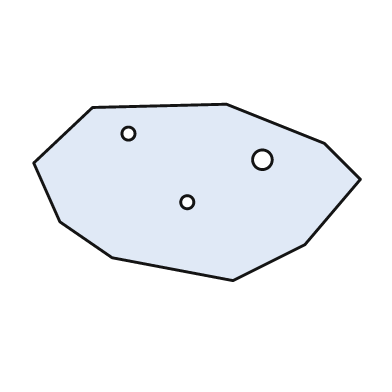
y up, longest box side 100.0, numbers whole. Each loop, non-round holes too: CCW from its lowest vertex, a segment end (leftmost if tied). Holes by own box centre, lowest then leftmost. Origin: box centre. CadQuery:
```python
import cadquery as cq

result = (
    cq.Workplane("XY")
    .moveTo(11.0, -27.0)
    .lineTo(33.0, -16.0)
    .lineTo(50.0, 4.0)
    .lineTo(39.0, 15.0)
    .lineTo(9.0, 27.0)
    .lineTo(-32.0, 26.0)
    .lineTo(-50.0, 9.0)
    .lineTo(-42.0, -9.0)
    .lineTo(-26.0, -20.0)
    .close()
    .moveTo(-3.0, -3.0)
    .circle(2.0)
    .moveTo(20.0, 10.0)
    .circle(3.0)
    .moveTo(-21.0, 18.0)
    .circle(2.0)
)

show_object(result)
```